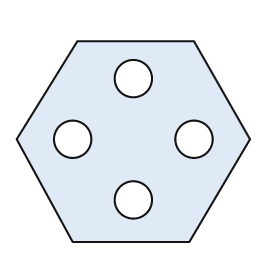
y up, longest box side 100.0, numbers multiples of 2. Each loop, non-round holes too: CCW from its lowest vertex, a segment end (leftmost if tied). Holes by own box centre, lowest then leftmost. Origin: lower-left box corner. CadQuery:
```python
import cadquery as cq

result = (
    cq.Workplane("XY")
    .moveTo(24.0, 0.0)
    .lineTo(74.0, 0.0)
    .lineTo(100.0, 44.0)
    .lineTo(76.0, 86.0)
    .lineTo(26.0, 86.0)
    .lineTo(0.0, 44.0)
    .close()
    .moveTo(50.0, 18.0)
    .circle(8.0)
    .moveTo(24.0, 44.0)
    .circle(8.0)
    .moveTo(76.0, 44.0)
    .circle(8.0)
    .moveTo(50.0, 70.0)
    .circle(8.0)
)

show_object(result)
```